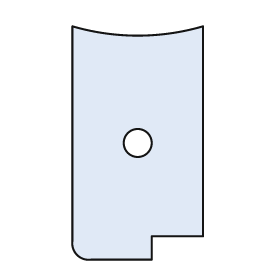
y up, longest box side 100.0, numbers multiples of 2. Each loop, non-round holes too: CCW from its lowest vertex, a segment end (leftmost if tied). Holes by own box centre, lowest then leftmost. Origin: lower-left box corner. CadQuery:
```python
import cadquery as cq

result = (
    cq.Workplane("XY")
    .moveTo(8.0, 0.0)
    .lineTo(34.0, 0.0)
    .lineTo(34.0, 10.0)
    .lineTo(56.0, 10.0)
    .lineTo(56.0, 100.0)
    .threePointArc((28.0, 96.0), (0.0, 100.0))
    .lineTo(0.0, 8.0)
    .threePointArc((2.0, 2.0), (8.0, 0.0))
    .close()
    .moveTo(28.0, 50.0)
    .circle(6.0)
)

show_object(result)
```